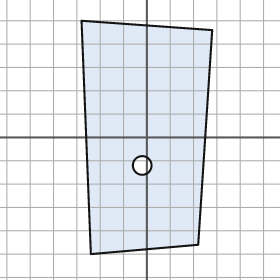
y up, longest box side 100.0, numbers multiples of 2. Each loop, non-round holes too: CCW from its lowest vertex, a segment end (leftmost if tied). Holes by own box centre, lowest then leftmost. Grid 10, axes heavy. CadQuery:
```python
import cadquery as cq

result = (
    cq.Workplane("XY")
    .moveTo(-24.0, -50.0)
    .lineTo(22.0, -46.0)
    .lineTo(28.0, 46.0)
    .lineTo(-28.0, 50.0)
    .close()
    .moveTo(-2.0, -12.0)
    .circle(4.0)
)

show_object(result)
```